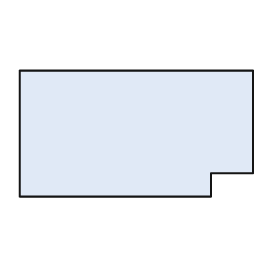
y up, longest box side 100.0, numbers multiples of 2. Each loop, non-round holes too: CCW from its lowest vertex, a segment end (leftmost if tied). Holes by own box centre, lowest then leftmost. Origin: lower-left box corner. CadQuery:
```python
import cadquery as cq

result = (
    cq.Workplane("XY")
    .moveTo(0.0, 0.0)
    .lineTo(82.0, 0.0)
    .lineTo(82.0, 10.0)
    .lineTo(100.0, 10.0)
    .lineTo(100.0, 54.0)
    .lineTo(0.0, 54.0)
    .close()
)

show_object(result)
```